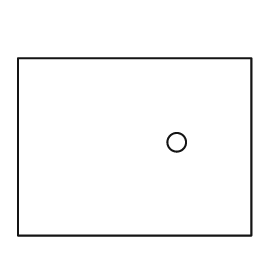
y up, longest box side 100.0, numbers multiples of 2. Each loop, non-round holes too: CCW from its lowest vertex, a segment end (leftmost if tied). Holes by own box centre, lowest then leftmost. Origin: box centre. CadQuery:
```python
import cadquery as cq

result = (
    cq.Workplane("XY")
    .moveTo(-50.0, -38.0)
    .lineTo(50.0, -38.0)
    .lineTo(50.0, 38.0)
    .lineTo(-50.0, 38.0)
    .close()
    .moveTo(18.0, 2.0)
    .circle(4.0)
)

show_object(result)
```